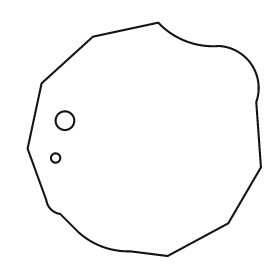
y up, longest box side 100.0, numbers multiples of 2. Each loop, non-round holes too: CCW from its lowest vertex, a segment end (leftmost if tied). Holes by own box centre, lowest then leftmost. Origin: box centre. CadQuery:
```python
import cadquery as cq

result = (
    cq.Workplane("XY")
    .moveTo(10.0, -50.0)
    .lineTo(36.0, -36.0)
    .lineTo(50.0, -12.0)
    .lineTo(48.0, 16.0)
    .threePointArc((46.0, 32.0), (32.0, 40.0))
    .threePointArc((18.0, 42.0), (6.0, 50.0))
    .lineTo(-22.0, 44.0)
    .lineTo(-44.0, 24.0)
    .lineTo(-50.0, -4.0)
    .lineTo(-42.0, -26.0)
    .threePointArc((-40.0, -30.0), (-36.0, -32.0))
    .lineTo(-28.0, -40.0)
    .threePointArc((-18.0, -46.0), (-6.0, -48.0))
    .close()
    .moveTo(-38.0, -8.0)
    .circle(2.0)
    .moveTo(-34.0, 8.0)
    .circle(4.0)
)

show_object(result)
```